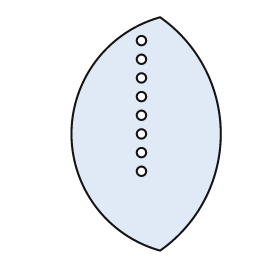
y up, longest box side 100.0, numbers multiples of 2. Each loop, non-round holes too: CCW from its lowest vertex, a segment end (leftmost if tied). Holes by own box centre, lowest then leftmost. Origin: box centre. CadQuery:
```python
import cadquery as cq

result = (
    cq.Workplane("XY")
    .moveTo(6.0, -50.0)
    .threePointArc((32.0, 0.0), (6.0, 50.0))
    .threePointArc((-32.0, 0.0), (6.0, -50.0))
    .close()
    .moveTo(-2.0, -16.0)
    .circle(2.0)
    .moveTo(-2.0, -8.0)
    .circle(2.0)
    .moveTo(-2.0, 0.0)
    .circle(2.0)
    .moveTo(-2.0, 8.0)
    .circle(2.0)
    .moveTo(-2.0, 16.0)
    .circle(2.0)
    .moveTo(-2.0, 24.0)
    .circle(2.0)
    .moveTo(-2.0, 32.0)
    .circle(2.0)
    .moveTo(-2.0, 40.0)
    .circle(2.0)
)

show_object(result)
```